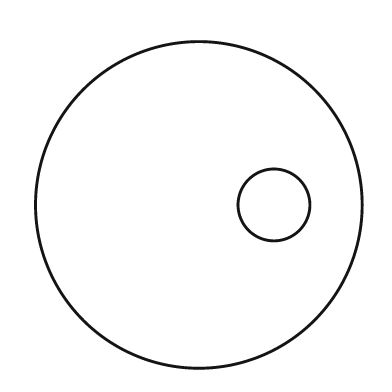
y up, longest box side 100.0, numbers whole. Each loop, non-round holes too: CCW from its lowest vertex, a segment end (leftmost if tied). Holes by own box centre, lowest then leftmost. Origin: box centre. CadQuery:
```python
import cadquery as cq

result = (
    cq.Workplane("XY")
    .moveTo(0.0, 0.0)
    .circle(50.0)
    .moveTo(23.0, 0.0)
    .circle(11.0)
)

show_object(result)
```